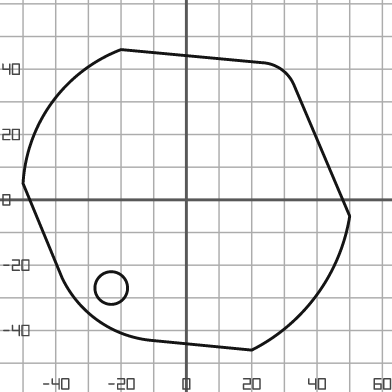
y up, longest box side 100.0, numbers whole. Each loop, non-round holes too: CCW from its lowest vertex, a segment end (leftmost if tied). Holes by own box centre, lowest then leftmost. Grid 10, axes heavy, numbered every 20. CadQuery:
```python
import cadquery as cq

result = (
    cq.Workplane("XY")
    .moveTo(20.0, -46.0)
    .threePointArc((40.0, -29.0), (50.0, -5.0))
    .lineTo(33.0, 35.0)
    .threePointArc((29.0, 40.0), (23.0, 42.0))
    .lineTo(-20.0, 46.0)
    .threePointArc((-41.0, 30.0), (-50.0, 5.0))
    .lineTo(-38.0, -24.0)
    .threePointArc((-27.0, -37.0), (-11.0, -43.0))
    .close()
    .moveTo(-23.0, -27.0)
    .circle(5.0)
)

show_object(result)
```